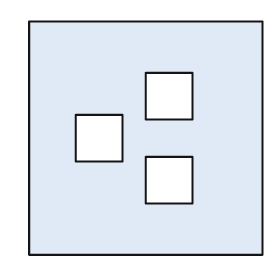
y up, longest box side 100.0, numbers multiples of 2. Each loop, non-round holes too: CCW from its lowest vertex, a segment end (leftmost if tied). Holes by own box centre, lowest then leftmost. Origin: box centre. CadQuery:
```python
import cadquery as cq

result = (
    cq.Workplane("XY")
    .moveTo(-50.0, -50.0)
    .lineTo(50.0, -50.0)
    .lineTo(50.0, 50.0)
    .lineTo(-50.0, 50.0)
    .close()
    .moveTo(0.0, -28.0)
    .lineTo(20.0, -28.0)
    .lineTo(20.0, -8.0)
    .lineTo(0.0, -8.0)
    .close()
    .moveTo(-30.0, -10.0)
    .lineTo(-10.0, -10.0)
    .lineTo(-10.0, 10.0)
    .lineTo(-30.0, 10.0)
    .close()
    .moveTo(0.0, 8.0)
    .lineTo(20.0, 8.0)
    .lineTo(20.0, 28.0)
    .lineTo(0.0, 28.0)
    .close()
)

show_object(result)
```